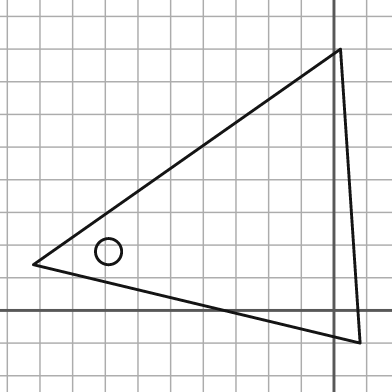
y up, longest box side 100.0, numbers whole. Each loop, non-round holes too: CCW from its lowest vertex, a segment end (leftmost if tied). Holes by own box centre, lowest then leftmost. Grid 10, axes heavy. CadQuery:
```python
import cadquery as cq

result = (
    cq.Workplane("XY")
    .moveTo(8.0, -10.0)
    .lineTo(2.0, 80.0)
    .lineTo(-92.0, 14.0)
    .close()
    .moveTo(-69.0, 18.0)
    .circle(4.0)
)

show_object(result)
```